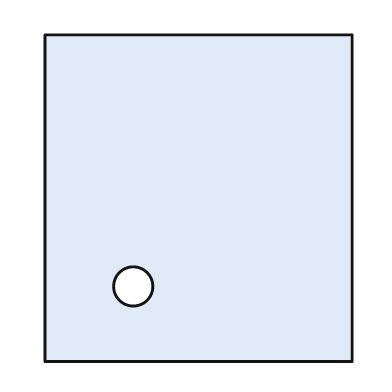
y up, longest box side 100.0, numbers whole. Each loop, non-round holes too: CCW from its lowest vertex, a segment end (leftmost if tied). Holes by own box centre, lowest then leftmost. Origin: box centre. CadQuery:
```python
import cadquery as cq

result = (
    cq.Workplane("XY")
    .moveTo(-47.0, -50.0)
    .lineTo(47.0, -50.0)
    .lineTo(47.0, 50.0)
    .lineTo(-47.0, 50.0)
    .close()
    .moveTo(-20.0, -27.0)
    .circle(6.0)
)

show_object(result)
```